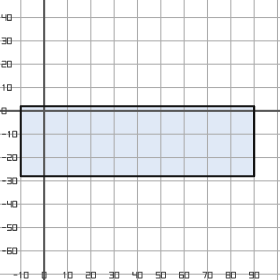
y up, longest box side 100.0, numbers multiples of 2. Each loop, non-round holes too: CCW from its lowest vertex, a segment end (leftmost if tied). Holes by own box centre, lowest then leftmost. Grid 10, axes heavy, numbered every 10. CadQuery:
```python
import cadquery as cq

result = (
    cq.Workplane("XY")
    .moveTo(-10.0, -28.0)
    .lineTo(90.0, -28.0)
    .lineTo(90.0, 2.0)
    .lineTo(-10.0, 2.0)
    .close()
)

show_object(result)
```